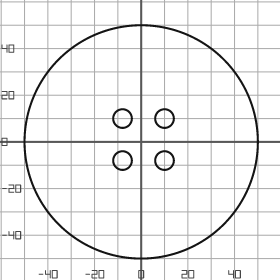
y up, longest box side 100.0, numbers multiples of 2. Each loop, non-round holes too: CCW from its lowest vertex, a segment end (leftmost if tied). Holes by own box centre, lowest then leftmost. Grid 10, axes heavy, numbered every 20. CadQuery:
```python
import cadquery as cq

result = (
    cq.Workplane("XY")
    .moveTo(0.0, 0.0)
    .circle(50.0)
    .moveTo(-8.0, -8.0)
    .circle(4.0)
    .moveTo(10.0, -8.0)
    .circle(4.0)
    .moveTo(-8.0, 10.0)
    .circle(4.0)
    .moveTo(10.0, 10.0)
    .circle(4.0)
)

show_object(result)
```